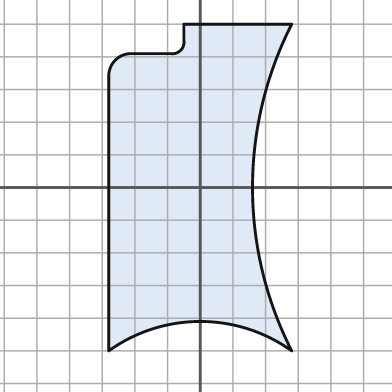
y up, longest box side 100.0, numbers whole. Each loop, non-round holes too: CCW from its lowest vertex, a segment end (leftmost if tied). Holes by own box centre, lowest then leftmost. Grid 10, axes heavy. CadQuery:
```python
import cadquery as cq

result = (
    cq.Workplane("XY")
    .moveTo(-28.0, -50.0)
    .threePointArc((0.0, -41.0), (28.0, -50.0))
    .threePointArc((16.0, 0.0), (28.0, 50.0))
    .lineTo(-5.0, 50.0)
    .lineTo(-5.0, 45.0)
    .threePointArc((-6.0, 42.0), (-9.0, 41.0))
    .lineTo(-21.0, 41.0)
    .threePointArc((-26.0, 39.0), (-28.0, 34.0))
    .close()
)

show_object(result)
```